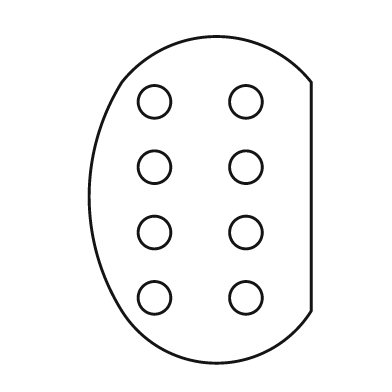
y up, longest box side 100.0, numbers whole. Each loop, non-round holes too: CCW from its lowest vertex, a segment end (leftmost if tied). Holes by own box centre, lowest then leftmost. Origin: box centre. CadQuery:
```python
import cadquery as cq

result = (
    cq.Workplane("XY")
    .moveTo(-24.0, -34.0)
    .threePointArc((5.0, -50.0), (34.0, -34.0))
    .lineTo(34.0, 36.0)
    .threePointArc((5.0, 50.0), (-24.0, 36.0))
    .threePointArc((-34.0, 1.0), (-24.0, -34.0))
    .close()
    .moveTo(-14.0, -30.0)
    .circle(5.0)
    .moveTo(14.0, -30.0)
    .circle(5.0)
    .moveTo(-14.0, -10.0)
    .circle(5.0)
    .moveTo(14.0, -10.0)
    .circle(5.0)
    .moveTo(-14.0, 10.0)
    .circle(5.0)
    .moveTo(14.0, 10.0)
    .circle(5.0)
    .moveTo(-14.0, 30.0)
    .circle(5.0)
    .moveTo(14.0, 30.0)
    .circle(5.0)
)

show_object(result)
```